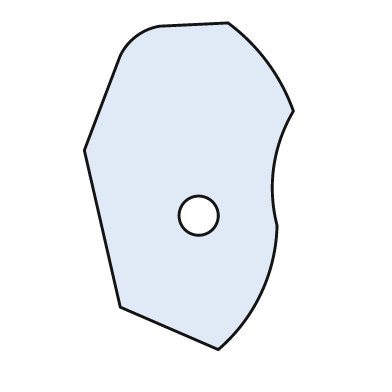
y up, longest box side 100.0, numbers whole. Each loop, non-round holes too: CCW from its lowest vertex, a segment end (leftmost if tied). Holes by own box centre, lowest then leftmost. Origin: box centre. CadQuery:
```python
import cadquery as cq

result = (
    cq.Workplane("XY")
    .moveTo(9.0, -50.0)
    .threePointArc((22.0, -33.0), (27.0, -12.0))
    .threePointArc((26.0, 6.0), (32.0, 23.0))
    .threePointArc((24.0, 38.0), (12.0, 50.0))
    .lineTo(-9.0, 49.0)
    .threePointArc((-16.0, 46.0), (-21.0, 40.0))
    .lineTo(-32.0, 11.0)
    .lineTo(-21.0, -37.0)
    .close()
    .moveTo(3.0, -9.0)
    .circle(6.0)
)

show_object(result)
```